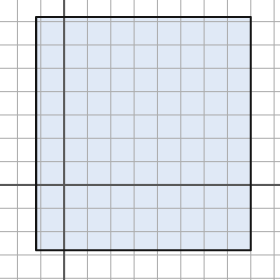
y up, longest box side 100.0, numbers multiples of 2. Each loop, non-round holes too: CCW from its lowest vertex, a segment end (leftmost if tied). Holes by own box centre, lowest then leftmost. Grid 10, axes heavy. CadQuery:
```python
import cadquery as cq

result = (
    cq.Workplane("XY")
    .moveTo(-12.0, -28.0)
    .lineTo(80.0, -28.0)
    .lineTo(80.0, 72.0)
    .lineTo(-12.0, 72.0)
    .close()
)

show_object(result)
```